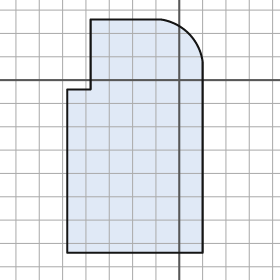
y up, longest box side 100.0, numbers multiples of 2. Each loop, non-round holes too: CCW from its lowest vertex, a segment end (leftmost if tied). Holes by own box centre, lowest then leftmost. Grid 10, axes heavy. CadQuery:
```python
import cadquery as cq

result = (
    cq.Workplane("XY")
    .moveTo(-48.0, -74.0)
    .lineTo(10.0, -74.0)
    .lineTo(10.0, 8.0)
    .threePointArc((4.0, 20.0), (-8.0, 26.0))
    .lineTo(-38.0, 26.0)
    .lineTo(-38.0, -4.0)
    .lineTo(-48.0, -4.0)
    .close()
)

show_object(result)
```